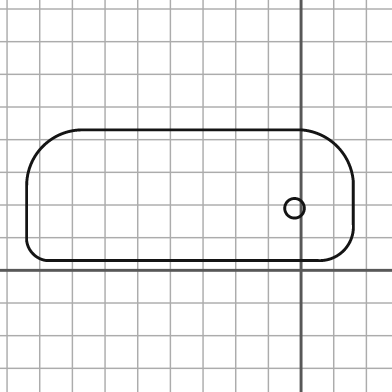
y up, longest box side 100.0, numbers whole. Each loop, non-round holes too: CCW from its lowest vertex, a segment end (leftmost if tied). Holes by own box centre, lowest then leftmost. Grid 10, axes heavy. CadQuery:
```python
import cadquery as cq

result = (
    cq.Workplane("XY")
    .moveTo(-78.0, 3.0)
    .lineTo(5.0, 3.0)
    .threePointArc((13.0, 6.0), (16.0, 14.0))
    .lineTo(16.0, 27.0)
    .threePointArc((11.0, 38.0), (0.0, 43.0))
    .lineTo(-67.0, 43.0)
    .threePointArc((-79.0, 38.0), (-84.0, 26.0))
    .lineTo(-84.0, 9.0)
    .threePointArc((-82.0, 5.0), (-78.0, 3.0))
    .close()
    .moveTo(-2.0, 19.0)
    .circle(3.0)
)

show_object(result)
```